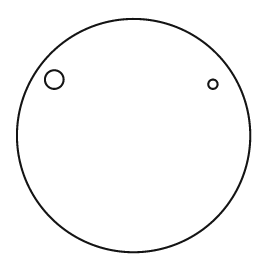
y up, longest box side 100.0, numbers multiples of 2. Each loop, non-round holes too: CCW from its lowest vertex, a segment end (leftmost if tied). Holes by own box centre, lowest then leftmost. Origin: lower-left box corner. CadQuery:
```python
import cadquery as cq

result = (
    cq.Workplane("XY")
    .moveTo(50.0, 50.0)
    .circle(50.0)
    .moveTo(84.0, 72.0)
    .circle(2.0)
    .moveTo(16.0, 74.0)
    .circle(4.0)
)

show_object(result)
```